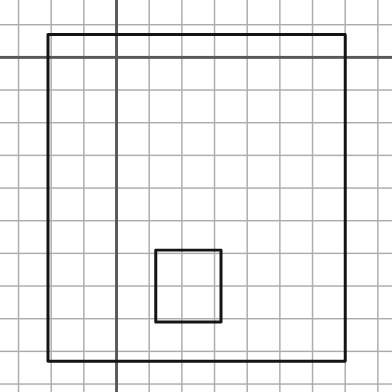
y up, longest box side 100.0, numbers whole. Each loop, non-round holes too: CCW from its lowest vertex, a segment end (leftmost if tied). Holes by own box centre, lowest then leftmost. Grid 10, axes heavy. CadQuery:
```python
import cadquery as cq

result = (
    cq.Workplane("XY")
    .moveTo(-21.0, -93.0)
    .lineTo(70.0, -93.0)
    .lineTo(70.0, 7.0)
    .lineTo(-21.0, 7.0)
    .close()
    .moveTo(12.0, -81.0)
    .lineTo(32.0, -81.0)
    .lineTo(32.0, -59.0)
    .lineTo(12.0, -59.0)
    .close()
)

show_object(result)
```